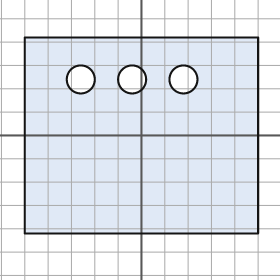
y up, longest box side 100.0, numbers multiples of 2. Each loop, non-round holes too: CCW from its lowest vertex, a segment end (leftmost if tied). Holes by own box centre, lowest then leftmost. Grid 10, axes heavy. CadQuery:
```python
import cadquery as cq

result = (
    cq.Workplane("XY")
    .moveTo(-50.0, -42.0)
    .lineTo(50.0, -42.0)
    .lineTo(50.0, 42.0)
    .lineTo(-50.0, 42.0)
    .close()
    .moveTo(-26.0, 24.0)
    .circle(6.0)
    .moveTo(-4.0, 24.0)
    .circle(6.0)
    .moveTo(18.0, 24.0)
    .circle(6.0)
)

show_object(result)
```